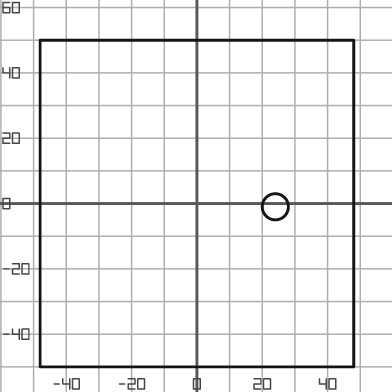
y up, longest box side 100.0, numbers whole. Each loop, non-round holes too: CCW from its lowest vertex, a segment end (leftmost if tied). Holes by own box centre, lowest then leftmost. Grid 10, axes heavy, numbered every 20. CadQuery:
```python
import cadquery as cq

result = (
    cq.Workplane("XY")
    .moveTo(-48.0, -50.0)
    .lineTo(48.0, -50.0)
    .lineTo(48.0, 50.0)
    .lineTo(-48.0, 50.0)
    .close()
    .moveTo(24.0, -1.0)
    .circle(4.0)
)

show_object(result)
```